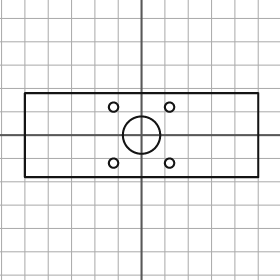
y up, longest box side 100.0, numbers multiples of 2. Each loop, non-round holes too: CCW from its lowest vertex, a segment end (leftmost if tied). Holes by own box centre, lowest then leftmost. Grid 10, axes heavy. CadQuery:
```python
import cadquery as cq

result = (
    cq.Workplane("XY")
    .moveTo(-50.0, -18.0)
    .lineTo(50.0, -18.0)
    .lineTo(50.0, 18.0)
    .lineTo(-50.0, 18.0)
    .close()
    .moveTo(-12.0, -12.0)
    .circle(2.0)
    .moveTo(12.0, -12.0)
    .circle(2.0)
    .moveTo(0.0, 0.0)
    .circle(8.0)
    .moveTo(-12.0, 12.0)
    .circle(2.0)
    .moveTo(12.0, 12.0)
    .circle(2.0)
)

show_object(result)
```